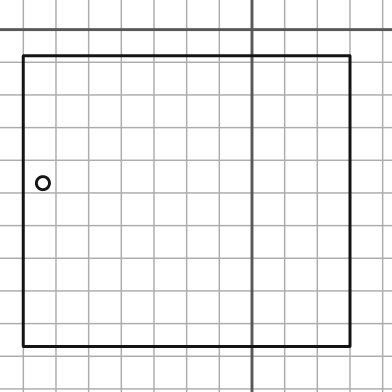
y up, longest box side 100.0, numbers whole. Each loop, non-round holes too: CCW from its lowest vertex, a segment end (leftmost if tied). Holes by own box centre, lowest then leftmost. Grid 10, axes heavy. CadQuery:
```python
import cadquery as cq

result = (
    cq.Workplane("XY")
    .moveTo(-70.0, -97.0)
    .lineTo(30.0, -97.0)
    .lineTo(30.0, -8.0)
    .lineTo(-70.0, -8.0)
    .close()
    .moveTo(-64.0, -47.0)
    .circle(2.0)
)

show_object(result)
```